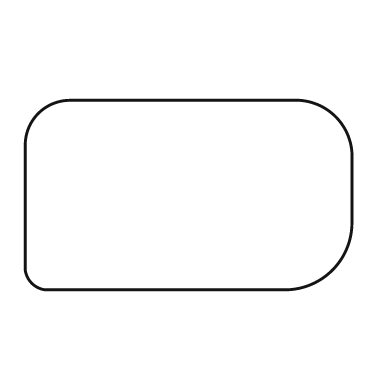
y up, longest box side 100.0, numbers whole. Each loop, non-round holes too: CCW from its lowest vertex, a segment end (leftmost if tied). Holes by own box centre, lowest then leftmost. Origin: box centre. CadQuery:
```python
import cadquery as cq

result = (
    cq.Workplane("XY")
    .moveTo(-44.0, -29.0)
    .lineTo(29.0, -29.0)
    .threePointArc((44.0, -23.0), (50.0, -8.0))
    .lineTo(50.0, 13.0)
    .threePointArc((45.0, 24.0), (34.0, 29.0))
    .lineTo(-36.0, 29.0)
    .threePointArc((-46.0, 25.0), (-50.0, 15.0))
    .lineTo(-50.0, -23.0)
    .threePointArc((-48.0, -27.0), (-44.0, -29.0))
    .close()
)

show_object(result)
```